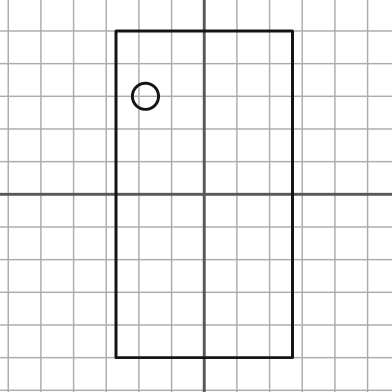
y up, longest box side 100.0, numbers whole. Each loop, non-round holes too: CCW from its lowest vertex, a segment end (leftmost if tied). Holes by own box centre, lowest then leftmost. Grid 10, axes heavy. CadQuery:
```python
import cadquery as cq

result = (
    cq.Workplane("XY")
    .moveTo(-27.0, -50.0)
    .lineTo(27.0, -50.0)
    .lineTo(27.0, 50.0)
    .lineTo(-27.0, 50.0)
    .close()
    .moveTo(-18.0, 30.0)
    .circle(4.0)
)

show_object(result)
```